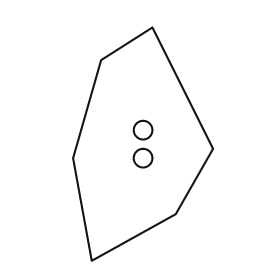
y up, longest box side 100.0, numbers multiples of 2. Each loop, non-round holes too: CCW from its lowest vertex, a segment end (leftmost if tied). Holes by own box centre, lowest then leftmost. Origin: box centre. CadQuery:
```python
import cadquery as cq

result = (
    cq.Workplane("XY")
    .moveTo(-22.0, -50.0)
    .lineTo(14.0, -30.0)
    .lineTo(30.0, -2.0)
    .lineTo(4.0, 50.0)
    .lineTo(-18.0, 36.0)
    .lineTo(-30.0, -6.0)
    .close()
    .moveTo(0.0, -6.0)
    .circle(4.0)
    .moveTo(0.0, 6.0)
    .circle(4.0)
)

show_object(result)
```